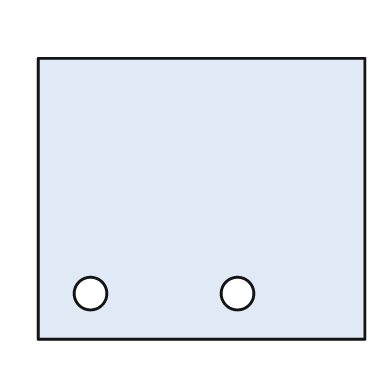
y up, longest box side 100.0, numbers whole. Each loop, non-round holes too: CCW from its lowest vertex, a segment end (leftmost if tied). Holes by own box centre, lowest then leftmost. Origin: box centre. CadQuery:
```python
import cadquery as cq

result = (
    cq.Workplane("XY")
    .moveTo(-50.0, -43.0)
    .lineTo(50.0, -43.0)
    .lineTo(50.0, 43.0)
    .lineTo(-50.0, 43.0)
    .close()
    .moveTo(-34.0, -29.0)
    .circle(5.0)
    .moveTo(11.0, -29.0)
    .circle(5.0)
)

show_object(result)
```